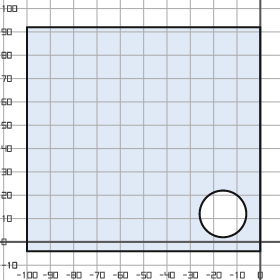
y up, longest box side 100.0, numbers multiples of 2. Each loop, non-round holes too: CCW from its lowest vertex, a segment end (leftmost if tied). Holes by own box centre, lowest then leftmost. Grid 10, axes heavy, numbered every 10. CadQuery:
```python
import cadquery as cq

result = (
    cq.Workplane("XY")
    .moveTo(-100.0, -4.0)
    .lineTo(0.0, -4.0)
    .lineTo(0.0, 92.0)
    .lineTo(-100.0, 92.0)
    .close()
    .moveTo(-16.0, 12.0)
    .circle(10.0)
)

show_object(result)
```